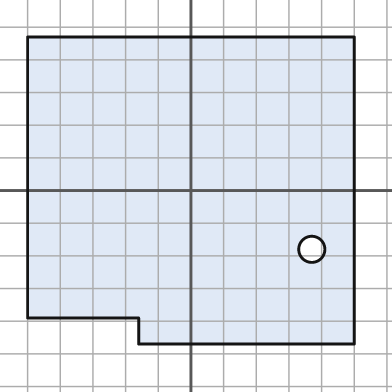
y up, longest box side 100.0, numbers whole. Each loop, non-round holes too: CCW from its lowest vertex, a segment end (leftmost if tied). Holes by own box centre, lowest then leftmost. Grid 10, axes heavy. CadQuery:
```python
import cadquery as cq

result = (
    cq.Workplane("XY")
    .moveTo(-16.0, -47.0)
    .lineTo(50.0, -47.0)
    .lineTo(50.0, 47.0)
    .lineTo(-50.0, 47.0)
    .lineTo(-50.0, -39.0)
    .lineTo(-16.0, -39.0)
    .close()
    .moveTo(37.0, -18.0)
    .circle(4.0)
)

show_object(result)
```